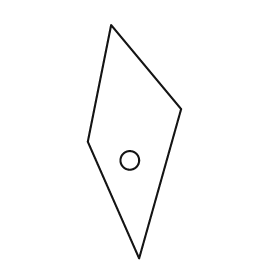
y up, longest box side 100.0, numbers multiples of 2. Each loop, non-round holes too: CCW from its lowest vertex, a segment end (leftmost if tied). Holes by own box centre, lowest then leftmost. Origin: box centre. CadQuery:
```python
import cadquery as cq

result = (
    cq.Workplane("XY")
    .moveTo(2.0, -50.0)
    .lineTo(20.0, 14.0)
    .lineTo(-10.0, 50.0)
    .lineTo(-20.0, 0.0)
    .close()
    .moveTo(-2.0, -8.0)
    .circle(4.0)
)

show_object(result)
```